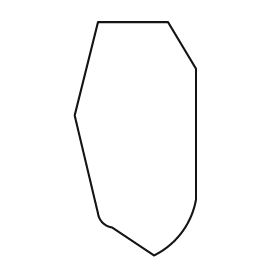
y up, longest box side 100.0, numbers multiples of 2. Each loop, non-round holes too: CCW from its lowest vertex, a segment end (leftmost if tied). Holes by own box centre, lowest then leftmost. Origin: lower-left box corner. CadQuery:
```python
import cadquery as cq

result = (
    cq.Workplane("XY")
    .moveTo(34.0, 0.0)
    .threePointArc((46.0, 10.0), (52.0, 24.0))
    .lineTo(52.0, 80.0)
    .lineTo(40.0, 100.0)
    .lineTo(10.0, 100.0)
    .lineTo(0.0, 60.0)
    .lineTo(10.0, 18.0)
    .threePointArc((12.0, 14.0), (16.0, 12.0))
    .close()
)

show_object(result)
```